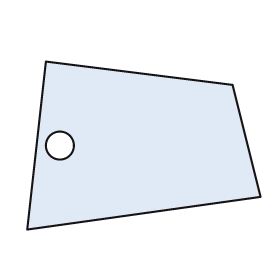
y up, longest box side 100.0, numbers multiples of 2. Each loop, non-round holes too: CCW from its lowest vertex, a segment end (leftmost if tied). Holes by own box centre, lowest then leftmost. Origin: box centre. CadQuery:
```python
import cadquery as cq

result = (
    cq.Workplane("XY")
    .moveTo(-50.0, -36.0)
    .lineTo(50.0, -22.0)
    .lineTo(38.0, 26.0)
    .lineTo(-42.0, 36.0)
    .close()
    .moveTo(-36.0, 0.0)
    .circle(6.0)
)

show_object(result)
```